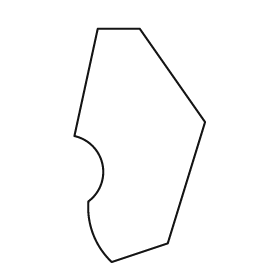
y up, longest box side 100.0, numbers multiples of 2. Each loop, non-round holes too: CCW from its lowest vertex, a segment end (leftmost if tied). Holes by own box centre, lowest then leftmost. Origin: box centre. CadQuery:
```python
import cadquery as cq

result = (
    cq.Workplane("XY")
    .moveTo(-12.0, -50.0)
    .lineTo(12.0, -42.0)
    .lineTo(28.0, 10.0)
    .lineTo(0.0, 50.0)
    .lineTo(-18.0, 50.0)
    .lineTo(-28.0, 4.0)
    .threePointArc((-16.0, -8.0), (-22.0, -24.0))
    .threePointArc((-20.0, -38.0), (-12.0, -50.0))
    .close()
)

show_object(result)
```